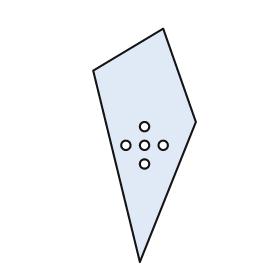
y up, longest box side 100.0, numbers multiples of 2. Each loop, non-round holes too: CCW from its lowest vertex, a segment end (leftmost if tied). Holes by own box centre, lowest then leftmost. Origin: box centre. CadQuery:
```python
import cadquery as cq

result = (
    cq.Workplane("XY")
    .moveTo(-2.0, -50.0)
    .lineTo(22.0, 10.0)
    .lineTo(8.0, 50.0)
    .lineTo(-22.0, 32.0)
    .close()
    .moveTo(0.0, -8.0)
    .circle(2.0)
    .moveTo(-8.0, 0.0)
    .circle(2.0)
    .moveTo(0.0, 0.0)
    .circle(2.0)
    .moveTo(8.0, 0.0)
    .circle(2.0)
    .moveTo(0.0, 8.0)
    .circle(2.0)
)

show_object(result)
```